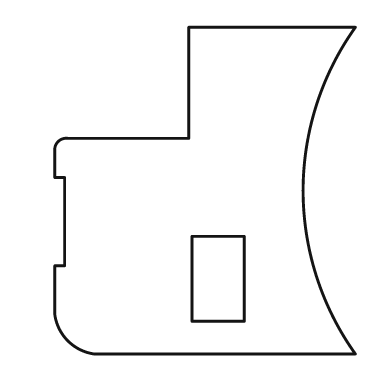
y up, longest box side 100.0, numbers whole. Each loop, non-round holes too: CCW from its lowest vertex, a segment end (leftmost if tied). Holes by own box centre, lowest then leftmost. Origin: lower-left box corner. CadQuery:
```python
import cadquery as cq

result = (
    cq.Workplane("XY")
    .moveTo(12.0, 0.0)
    .lineTo(92.0, 0.0)
    .threePointArc((76.0, 50.0), (92.0, 100.0))
    .lineTo(41.0, 100.0)
    .lineTo(41.0, 66.0)
    .lineTo(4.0, 66.0)
    .threePointArc((1.0, 65.0), (0.0, 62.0))
    .lineTo(0.0, 54.0)
    .lineTo(3.0, 54.0)
    .lineTo(3.0, 27.0)
    .lineTo(0.0, 27.0)
    .lineTo(0.0, 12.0)
    .threePointArc((4.0, 4.0), (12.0, 0.0))
    .close()
    .moveTo(42.0, 10.0)
    .lineTo(58.0, 10.0)
    .lineTo(58.0, 36.0)
    .lineTo(42.0, 36.0)
    .close()
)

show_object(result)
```